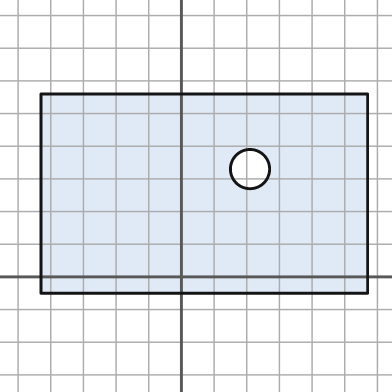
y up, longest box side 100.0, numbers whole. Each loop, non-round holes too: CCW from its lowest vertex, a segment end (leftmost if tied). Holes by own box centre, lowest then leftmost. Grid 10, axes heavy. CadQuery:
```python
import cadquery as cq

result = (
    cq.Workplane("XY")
    .moveTo(-43.0, -5.0)
    .lineTo(57.0, -5.0)
    .lineTo(57.0, 56.0)
    .lineTo(-43.0, 56.0)
    .close()
    .moveTo(21.0, 33.0)
    .circle(6.0)
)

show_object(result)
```